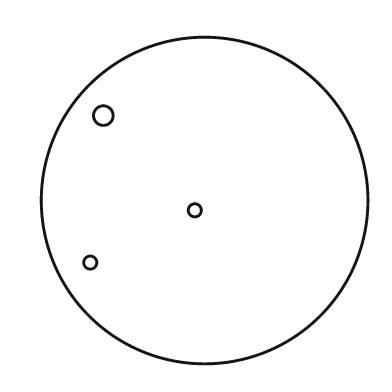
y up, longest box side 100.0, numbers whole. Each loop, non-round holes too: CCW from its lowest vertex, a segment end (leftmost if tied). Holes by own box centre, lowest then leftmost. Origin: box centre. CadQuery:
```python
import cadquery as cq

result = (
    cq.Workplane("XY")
    .moveTo(0.0, 0.0)
    .circle(50.0)
    .moveTo(-35.0, -19.0)
    .circle(2.0)
    .moveTo(-3.0, -3.0)
    .circle(2.0)
    .moveTo(-31.0, 26.0)
    .circle(3.0)
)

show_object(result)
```